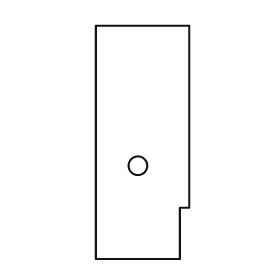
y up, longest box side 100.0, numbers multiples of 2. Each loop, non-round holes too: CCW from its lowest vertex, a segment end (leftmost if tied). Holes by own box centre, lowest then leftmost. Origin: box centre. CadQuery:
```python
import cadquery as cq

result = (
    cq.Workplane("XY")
    .moveTo(-20.0, -50.0)
    .lineTo(16.0, -50.0)
    .lineTo(16.0, -28.0)
    .lineTo(20.0, -28.0)
    .lineTo(20.0, 50.0)
    .lineTo(-20.0, 50.0)
    .close()
    .moveTo(-2.0, -10.0)
    .circle(4.0)
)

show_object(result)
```